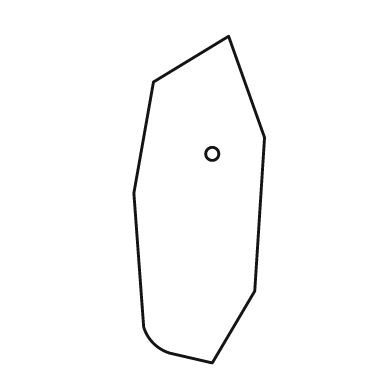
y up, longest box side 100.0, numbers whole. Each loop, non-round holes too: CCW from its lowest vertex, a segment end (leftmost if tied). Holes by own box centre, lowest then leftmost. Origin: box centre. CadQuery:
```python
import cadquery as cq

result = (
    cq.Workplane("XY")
    .moveTo(4.0, -50.0)
    .lineTo(17.0, -28.0)
    .lineTo(20.0, 19.0)
    .lineTo(9.0, 50.0)
    .lineTo(-14.0, 36.0)
    .lineTo(-20.0, 2.0)
    .lineTo(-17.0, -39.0)
    .threePointArc((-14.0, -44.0), (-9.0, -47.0))
    .close()
    .moveTo(4.0, 14.0)
    .circle(2.0)
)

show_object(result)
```